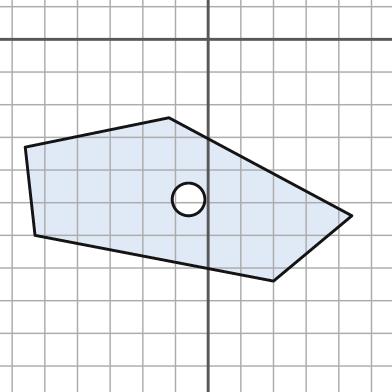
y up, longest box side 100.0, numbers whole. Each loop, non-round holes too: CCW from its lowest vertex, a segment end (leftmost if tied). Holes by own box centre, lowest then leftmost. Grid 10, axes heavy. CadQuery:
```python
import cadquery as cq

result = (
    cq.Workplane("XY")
    .moveTo(20.0, -74.0)
    .lineTo(44.0, -54.0)
    .lineTo(-12.0, -24.0)
    .lineTo(-56.0, -33.0)
    .lineTo(-53.0, -60.0)
    .close()
    .moveTo(-6.0, -49.0)
    .circle(5.0)
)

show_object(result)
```